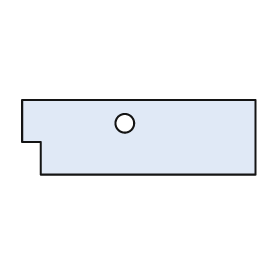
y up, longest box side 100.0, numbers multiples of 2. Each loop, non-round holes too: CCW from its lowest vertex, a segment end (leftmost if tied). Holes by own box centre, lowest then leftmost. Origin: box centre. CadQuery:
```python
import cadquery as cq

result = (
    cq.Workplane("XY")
    .moveTo(-42.0, -16.0)
    .lineTo(50.0, -16.0)
    .lineTo(50.0, 16.0)
    .lineTo(-50.0, 16.0)
    .lineTo(-50.0, -2.0)
    .lineTo(-42.0, -2.0)
    .close()
    .moveTo(-6.0, 6.0)
    .circle(4.0)
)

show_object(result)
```